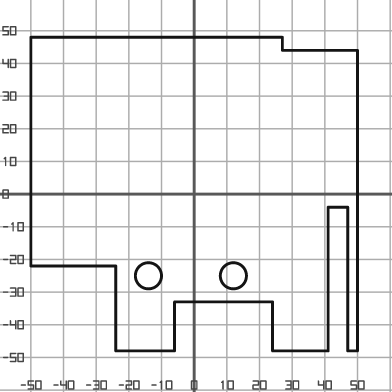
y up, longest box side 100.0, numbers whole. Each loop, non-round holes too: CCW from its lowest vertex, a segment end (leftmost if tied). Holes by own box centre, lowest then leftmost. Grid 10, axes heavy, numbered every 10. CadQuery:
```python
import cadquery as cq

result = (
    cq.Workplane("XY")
    .moveTo(-24.0, -48.0)
    .lineTo(-6.0, -48.0)
    .lineTo(-6.0, -33.0)
    .lineTo(24.0, -33.0)
    .lineTo(24.0, -48.0)
    .lineTo(41.0, -48.0)
    .lineTo(41.0, -4.0)
    .lineTo(47.0, -4.0)
    .lineTo(47.0, -48.0)
    .lineTo(50.0, -48.0)
    .lineTo(50.0, 44.0)
    .lineTo(27.0, 44.0)
    .lineTo(27.0, 48.0)
    .lineTo(-50.0, 48.0)
    .lineTo(-50.0, -22.0)
    .lineTo(-24.0, -22.0)
    .close()
    .moveTo(-14.0, -25.0)
    .circle(4.0)
    .moveTo(12.0, -25.0)
    .circle(4.0)
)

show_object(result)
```